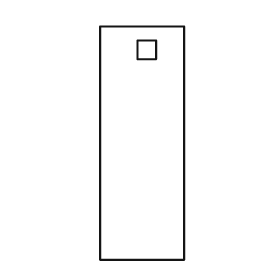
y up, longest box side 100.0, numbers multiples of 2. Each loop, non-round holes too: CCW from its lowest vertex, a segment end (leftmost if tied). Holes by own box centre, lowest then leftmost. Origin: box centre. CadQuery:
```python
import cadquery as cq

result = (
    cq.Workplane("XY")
    .moveTo(-18.0, -50.0)
    .lineTo(18.0, -50.0)
    .lineTo(18.0, 50.0)
    .lineTo(-18.0, 50.0)
    .close()
    .moveTo(-2.0, 36.0)
    .lineTo(6.0, 36.0)
    .lineTo(6.0, 44.0)
    .lineTo(-2.0, 44.0)
    .close()
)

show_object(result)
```